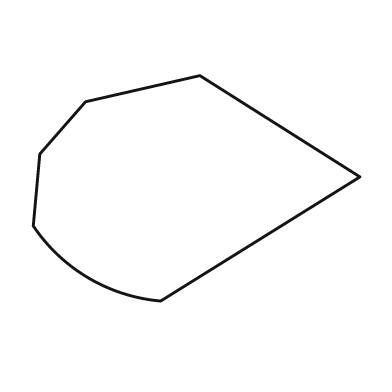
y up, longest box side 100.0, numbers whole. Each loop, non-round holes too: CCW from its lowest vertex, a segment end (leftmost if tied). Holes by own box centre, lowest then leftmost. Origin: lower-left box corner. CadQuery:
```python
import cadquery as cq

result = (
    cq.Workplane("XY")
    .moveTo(39.0, 0.0)
    .lineTo(100.0, 38.0)
    .lineTo(51.0, 69.0)
    .lineTo(16.0, 61.0)
    .lineTo(2.0, 45.0)
    .lineTo(0.0, 23.0)
    .threePointArc((17.0, 7.0), (39.0, 0.0))
    .close()
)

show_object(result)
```